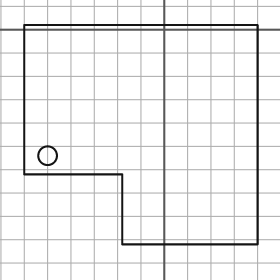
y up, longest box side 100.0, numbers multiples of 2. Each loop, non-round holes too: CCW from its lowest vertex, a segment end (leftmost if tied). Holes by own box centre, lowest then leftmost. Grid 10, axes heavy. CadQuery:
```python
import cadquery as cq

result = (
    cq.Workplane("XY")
    .moveTo(-18.0, -92.0)
    .lineTo(40.0, -92.0)
    .lineTo(40.0, 2.0)
    .lineTo(-60.0, 2.0)
    .lineTo(-60.0, -62.0)
    .lineTo(-18.0, -62.0)
    .close()
    .moveTo(-50.0, -54.0)
    .circle(4.0)
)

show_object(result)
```